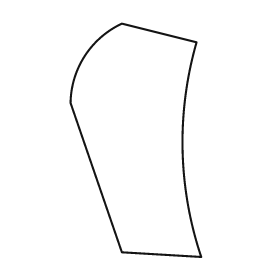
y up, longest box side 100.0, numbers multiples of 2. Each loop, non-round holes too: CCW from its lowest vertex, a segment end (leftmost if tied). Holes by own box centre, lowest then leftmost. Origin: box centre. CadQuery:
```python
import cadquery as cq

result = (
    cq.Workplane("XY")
    .moveTo(28.0, -50.0)
    .threePointArc((20.0, -4.0), (26.0, 42.0))
    .lineTo(-6.0, 50.0)
    .threePointArc((-22.0, 36.0), (-28.0, 16.0))
    .lineTo(-6.0, -48.0)
    .close()
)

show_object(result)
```